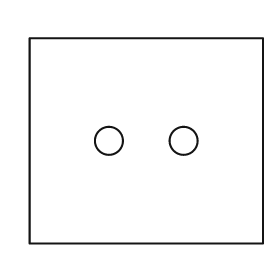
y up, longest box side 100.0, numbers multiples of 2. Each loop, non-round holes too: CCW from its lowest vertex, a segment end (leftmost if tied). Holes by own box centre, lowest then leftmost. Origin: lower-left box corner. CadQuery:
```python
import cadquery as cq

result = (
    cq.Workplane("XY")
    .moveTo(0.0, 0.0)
    .lineTo(100.0, 0.0)
    .lineTo(100.0, 88.0)
    .lineTo(0.0, 88.0)
    .close()
    .moveTo(34.0, 44.0)
    .circle(6.0)
    .moveTo(66.0, 44.0)
    .circle(6.0)
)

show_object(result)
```